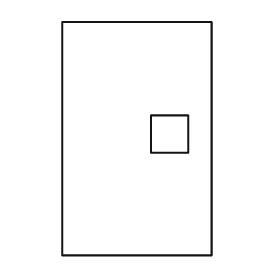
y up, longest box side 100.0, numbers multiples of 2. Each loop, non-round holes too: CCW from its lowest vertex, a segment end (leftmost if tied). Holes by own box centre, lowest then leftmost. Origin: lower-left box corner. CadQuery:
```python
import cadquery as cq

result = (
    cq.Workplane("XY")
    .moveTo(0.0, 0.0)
    .lineTo(64.0, 0.0)
    .lineTo(64.0, 100.0)
    .lineTo(0.0, 100.0)
    .close()
    .moveTo(38.0, 44.0)
    .lineTo(54.0, 44.0)
    .lineTo(54.0, 60.0)
    .lineTo(38.0, 60.0)
    .close()
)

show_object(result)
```